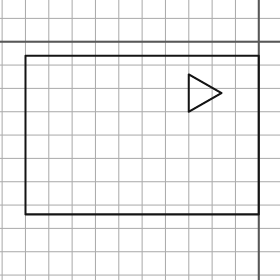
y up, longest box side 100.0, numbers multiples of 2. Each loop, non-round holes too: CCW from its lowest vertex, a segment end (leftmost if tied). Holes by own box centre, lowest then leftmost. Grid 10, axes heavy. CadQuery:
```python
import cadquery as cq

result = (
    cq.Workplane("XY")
    .moveTo(-100.0, -74.0)
    .lineTo(0.0, -74.0)
    .lineTo(0.0, -6.0)
    .lineTo(-100.0, -6.0)
    .close()
    .moveTo(-30.0, -30.0)
    .lineTo(-16.0, -22.0)
    .lineTo(-30.0, -14.0)
    .close()
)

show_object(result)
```